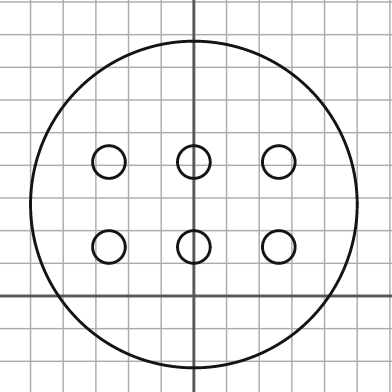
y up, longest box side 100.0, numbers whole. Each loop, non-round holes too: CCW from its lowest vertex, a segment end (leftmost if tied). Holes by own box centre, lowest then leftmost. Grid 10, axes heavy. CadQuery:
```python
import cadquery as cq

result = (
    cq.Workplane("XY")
    .moveTo(0.0, 28.0)
    .circle(50.0)
    .moveTo(-26.0, 15.0)
    .circle(5.0)
    .moveTo(0.0, 15.0)
    .circle(5.0)
    .moveTo(26.0, 15.0)
    .circle(5.0)
    .moveTo(-26.0, 41.0)
    .circle(5.0)
    .moveTo(0.0, 41.0)
    .circle(5.0)
    .moveTo(26.0, 41.0)
    .circle(5.0)
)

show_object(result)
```